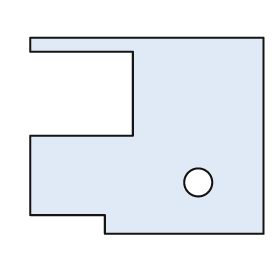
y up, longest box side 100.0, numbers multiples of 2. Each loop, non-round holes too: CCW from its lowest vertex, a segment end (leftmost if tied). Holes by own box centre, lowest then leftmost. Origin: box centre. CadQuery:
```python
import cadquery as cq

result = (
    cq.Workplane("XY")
    .moveTo(-18.0, -42.0)
    .lineTo(50.0, -42.0)
    .lineTo(50.0, 42.0)
    .lineTo(-50.0, 42.0)
    .lineTo(-50.0, 36.0)
    .lineTo(-6.0, 36.0)
    .lineTo(-6.0, 0.0)
    .lineTo(-50.0, 0.0)
    .lineTo(-50.0, -34.0)
    .lineTo(-18.0, -34.0)
    .close()
    .moveTo(22.0, -20.0)
    .circle(6.0)
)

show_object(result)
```